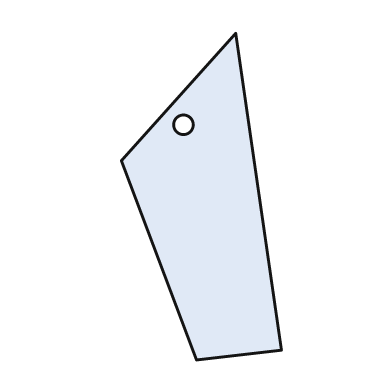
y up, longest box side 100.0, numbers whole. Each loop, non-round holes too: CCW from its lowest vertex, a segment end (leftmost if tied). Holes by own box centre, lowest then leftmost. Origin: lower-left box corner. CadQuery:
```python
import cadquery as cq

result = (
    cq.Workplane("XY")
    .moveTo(23.0, 0.0)
    .lineTo(49.0, 3.0)
    .lineTo(35.0, 100.0)
    .lineTo(0.0, 61.0)
    .close()
    .moveTo(19.0, 72.0)
    .circle(3.0)
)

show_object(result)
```